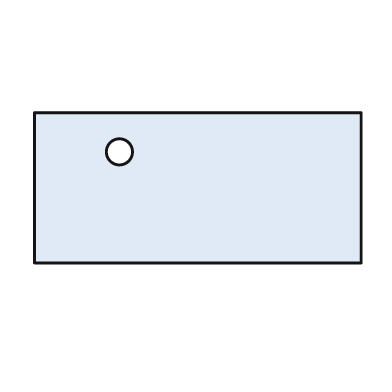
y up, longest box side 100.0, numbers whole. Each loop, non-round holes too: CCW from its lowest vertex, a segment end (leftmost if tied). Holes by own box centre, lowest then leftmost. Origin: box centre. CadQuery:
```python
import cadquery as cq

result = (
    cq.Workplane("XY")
    .moveTo(-50.0, -23.0)
    .lineTo(50.0, -23.0)
    .lineTo(50.0, 23.0)
    .lineTo(-50.0, 23.0)
    .close()
    .moveTo(-24.0, 11.0)
    .circle(4.0)
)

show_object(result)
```